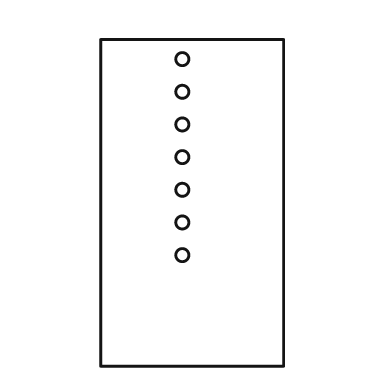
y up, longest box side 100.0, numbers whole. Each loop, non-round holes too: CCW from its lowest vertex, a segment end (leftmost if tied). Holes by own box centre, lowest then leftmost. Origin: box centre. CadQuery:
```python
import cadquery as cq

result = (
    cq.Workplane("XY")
    .moveTo(-28.0, -50.0)
    .lineTo(28.0, -50.0)
    .lineTo(28.0, 50.0)
    .lineTo(-28.0, 50.0)
    .close()
    .moveTo(-3.0, -16.0)
    .circle(2.0)
    .moveTo(-3.0, -6.0)
    .circle(2.0)
    .moveTo(-3.0, 4.0)
    .circle(2.0)
    .moveTo(-3.0, 14.0)
    .circle(2.0)
    .moveTo(-3.0, 24.0)
    .circle(2.0)
    .moveTo(-3.0, 34.0)
    .circle(2.0)
    .moveTo(-3.0, 44.0)
    .circle(2.0)
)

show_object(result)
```